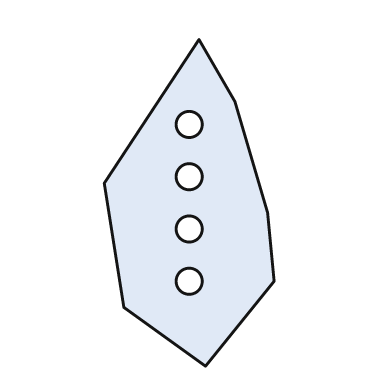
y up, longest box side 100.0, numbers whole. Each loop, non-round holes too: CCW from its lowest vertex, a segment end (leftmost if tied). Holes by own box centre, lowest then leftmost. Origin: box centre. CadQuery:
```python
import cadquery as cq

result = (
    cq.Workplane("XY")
    .moveTo(5.0, -50.0)
    .lineTo(26.0, -24.0)
    .lineTo(24.0, -3.0)
    .lineTo(14.0, 31.0)
    .lineTo(3.0, 50.0)
    .lineTo(-26.0, 6.0)
    .lineTo(-20.0, -32.0)
    .close()
    .moveTo(0.0, -24.0)
    .circle(4.0)
    .moveTo(0.0, -8.0)
    .circle(4.0)
    .moveTo(0.0, 8.0)
    .circle(4.0)
    .moveTo(0.0, 24.0)
    .circle(4.0)
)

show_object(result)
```